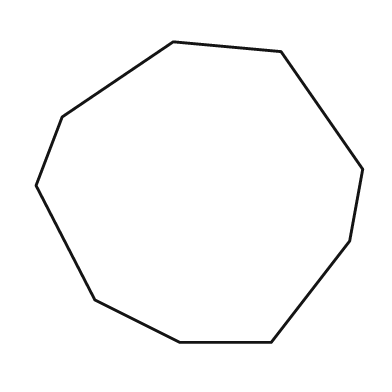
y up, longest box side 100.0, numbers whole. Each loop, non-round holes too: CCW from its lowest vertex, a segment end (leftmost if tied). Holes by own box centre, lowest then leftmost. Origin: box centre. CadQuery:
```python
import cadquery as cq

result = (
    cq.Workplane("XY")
    .moveTo(-6.0, -46.0)
    .lineTo(22.0, -46.0)
    .lineTo(46.0, -15.0)
    .lineTo(50.0, 7.0)
    .lineTo(25.0, 43.0)
    .lineTo(-8.0, 46.0)
    .lineTo(-42.0, 23.0)
    .lineTo(-50.0, 2.0)
    .lineTo(-32.0, -33.0)
    .close()
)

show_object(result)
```